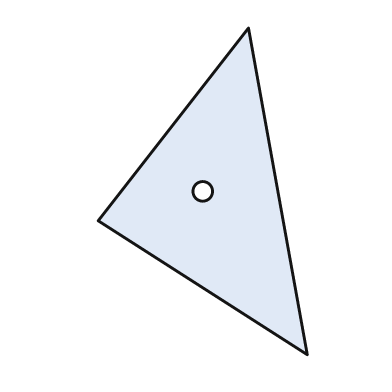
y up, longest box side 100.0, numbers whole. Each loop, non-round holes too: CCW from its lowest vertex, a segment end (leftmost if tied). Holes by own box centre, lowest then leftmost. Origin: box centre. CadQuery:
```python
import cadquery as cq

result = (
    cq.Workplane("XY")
    .moveTo(32.0, -50.0)
    .lineTo(14.0, 50.0)
    .lineTo(-32.0, -9.0)
    .close()
    .moveTo(0.0, 0.0)
    .circle(3.0)
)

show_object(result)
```